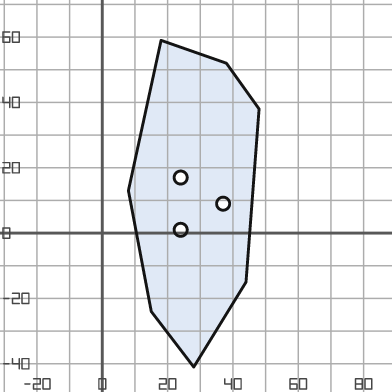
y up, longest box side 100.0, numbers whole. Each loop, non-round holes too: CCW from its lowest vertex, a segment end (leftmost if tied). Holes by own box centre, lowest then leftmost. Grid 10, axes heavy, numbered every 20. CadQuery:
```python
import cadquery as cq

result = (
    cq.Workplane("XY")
    .moveTo(28.0, -41.0)
    .lineTo(44.0, -15.0)
    .lineTo(48.0, 38.0)
    .lineTo(38.0, 52.0)
    .lineTo(18.0, 59.0)
    .lineTo(8.0, 13.0)
    .lineTo(15.0, -24.0)
    .close()
    .moveTo(24.0, 1.0)
    .circle(2.0)
    .moveTo(37.0, 9.0)
    .circle(2.0)
    .moveTo(24.0, 17.0)
    .circle(2.0)
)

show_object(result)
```